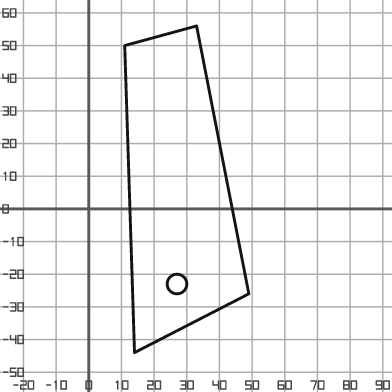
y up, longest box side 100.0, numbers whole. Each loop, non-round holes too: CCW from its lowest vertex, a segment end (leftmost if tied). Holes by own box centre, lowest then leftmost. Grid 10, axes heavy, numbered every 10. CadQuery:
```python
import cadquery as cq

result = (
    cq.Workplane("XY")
    .moveTo(14.0, -44.0)
    .lineTo(49.0, -26.0)
    .lineTo(33.0, 56.0)
    .lineTo(11.0, 50.0)
    .close()
    .moveTo(27.0, -23.0)
    .circle(3.0)
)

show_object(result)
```